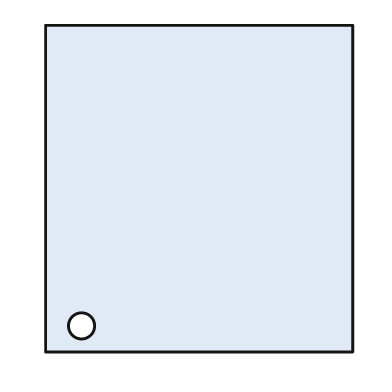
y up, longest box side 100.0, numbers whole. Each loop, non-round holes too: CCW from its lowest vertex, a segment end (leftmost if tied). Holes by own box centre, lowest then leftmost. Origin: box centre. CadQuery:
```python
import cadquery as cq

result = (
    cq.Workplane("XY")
    .moveTo(-47.0, -50.0)
    .lineTo(47.0, -50.0)
    .lineTo(47.0, 50.0)
    .lineTo(-47.0, 50.0)
    .close()
    .moveTo(-36.0, -42.0)
    .circle(4.0)
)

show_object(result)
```